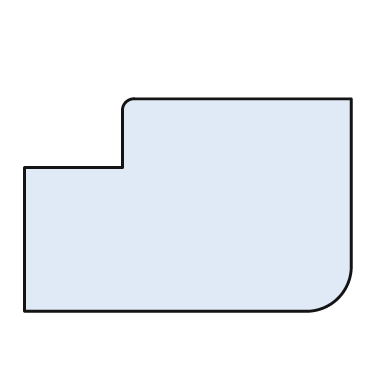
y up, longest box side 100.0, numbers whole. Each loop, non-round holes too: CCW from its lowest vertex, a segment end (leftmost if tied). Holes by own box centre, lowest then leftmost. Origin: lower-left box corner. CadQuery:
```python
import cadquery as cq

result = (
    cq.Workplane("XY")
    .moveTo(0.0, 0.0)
    .lineTo(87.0, 0.0)
    .threePointArc((96.0, 4.0), (100.0, 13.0))
    .lineTo(100.0, 65.0)
    .lineTo(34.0, 65.0)
    .threePointArc((31.0, 64.0), (30.0, 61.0))
    .lineTo(30.0, 44.0)
    .lineTo(0.0, 44.0)
    .close()
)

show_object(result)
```